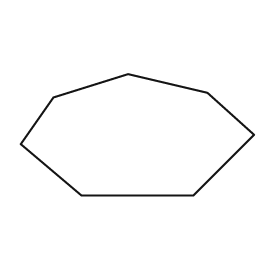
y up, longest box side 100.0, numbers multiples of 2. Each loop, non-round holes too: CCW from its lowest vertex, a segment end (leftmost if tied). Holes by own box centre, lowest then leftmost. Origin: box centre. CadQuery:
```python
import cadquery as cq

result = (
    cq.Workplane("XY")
    .moveTo(-24.0, -26.0)
    .lineTo(24.0, -26.0)
    .lineTo(50.0, 0.0)
    .lineTo(30.0, 18.0)
    .lineTo(-4.0, 26.0)
    .lineTo(-36.0, 16.0)
    .lineTo(-50.0, -4.0)
    .close()
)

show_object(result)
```